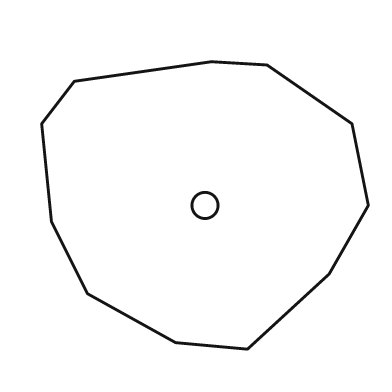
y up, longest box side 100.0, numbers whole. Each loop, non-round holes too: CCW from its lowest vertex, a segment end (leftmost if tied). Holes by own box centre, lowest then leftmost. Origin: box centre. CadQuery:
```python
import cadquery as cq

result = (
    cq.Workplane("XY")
    .moveTo(13.0, -44.0)
    .lineTo(38.0, -21.0)
    .lineTo(50.0, 0.0)
    .lineTo(45.0, 25.0)
    .lineTo(19.0, 43.0)
    .lineTo(2.0, 44.0)
    .lineTo(-40.0, 38.0)
    .lineTo(-50.0, 25.0)
    .lineTo(-47.0, -5.0)
    .lineTo(-36.0, -27.0)
    .lineTo(-9.0, -42.0)
    .close()
    .moveTo(0.0, 0.0)
    .circle(4.0)
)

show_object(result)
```